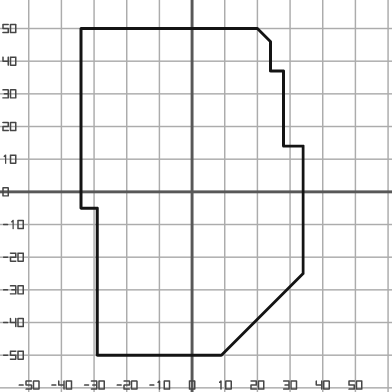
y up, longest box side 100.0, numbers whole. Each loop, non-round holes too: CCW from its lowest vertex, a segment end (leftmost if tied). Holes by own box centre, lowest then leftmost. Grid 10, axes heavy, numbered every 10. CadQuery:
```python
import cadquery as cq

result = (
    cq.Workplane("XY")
    .moveTo(-29.0, -50.0)
    .lineTo(9.0, -50.0)
    .lineTo(34.0, -25.0)
    .lineTo(34.0, 14.0)
    .lineTo(28.0, 14.0)
    .lineTo(28.0, 37.0)
    .lineTo(24.0, 37.0)
    .lineTo(24.0, 46.0)
    .lineTo(20.0, 50.0)
    .lineTo(-34.0, 50.0)
    .lineTo(-34.0, -5.0)
    .lineTo(-29.0, -5.0)
    .close()
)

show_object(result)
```